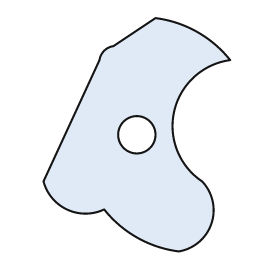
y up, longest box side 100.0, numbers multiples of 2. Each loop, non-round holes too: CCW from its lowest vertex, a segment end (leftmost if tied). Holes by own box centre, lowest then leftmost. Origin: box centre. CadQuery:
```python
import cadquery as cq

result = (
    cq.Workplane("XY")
    .moveTo(18.0, -50.0)
    .threePointArc((32.0, -38.0), (28.0, -20.0))
    .threePointArc((16.0, 10.0), (40.0, 32.0))
    .threePointArc((26.0, 44.0), (8.0, 50.0))
    .lineTo(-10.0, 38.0)
    .threePointArc((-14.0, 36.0), (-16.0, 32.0))
    .lineTo(-40.0, -20.0)
    .threePointArc((-30.0, -32.0), (-14.0, -32.0))
    .threePointArc((0.0, -44.0), (18.0, -50.0))
    .close()
    .moveTo(0.0, 0.0)
    .circle(8.0)
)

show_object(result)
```